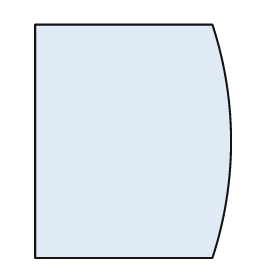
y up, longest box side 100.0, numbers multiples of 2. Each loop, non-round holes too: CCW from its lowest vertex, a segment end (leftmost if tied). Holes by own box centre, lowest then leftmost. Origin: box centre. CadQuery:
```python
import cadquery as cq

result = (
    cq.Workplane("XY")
    .moveTo(-42.0, -50.0)
    .lineTo(34.0, -50.0)
    .threePointArc((42.0, 0.0), (34.0, 50.0))
    .lineTo(-42.0, 50.0)
    .close()
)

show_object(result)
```